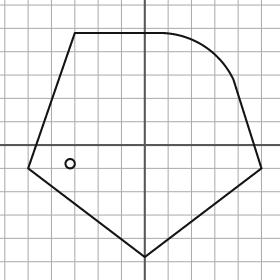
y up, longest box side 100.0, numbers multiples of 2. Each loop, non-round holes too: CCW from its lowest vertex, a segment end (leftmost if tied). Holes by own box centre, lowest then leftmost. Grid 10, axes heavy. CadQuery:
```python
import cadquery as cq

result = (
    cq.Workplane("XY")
    .moveTo(0.0, -48.0)
    .lineTo(50.0, -10.0)
    .lineTo(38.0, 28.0)
    .threePointArc((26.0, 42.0), (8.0, 48.0))
    .lineTo(-30.0, 48.0)
    .lineTo(-50.0, -10.0)
    .close()
    .moveTo(-32.0, -8.0)
    .circle(2.0)
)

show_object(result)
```